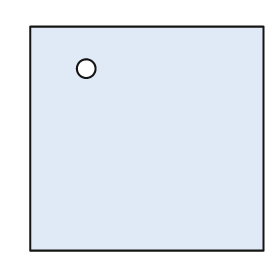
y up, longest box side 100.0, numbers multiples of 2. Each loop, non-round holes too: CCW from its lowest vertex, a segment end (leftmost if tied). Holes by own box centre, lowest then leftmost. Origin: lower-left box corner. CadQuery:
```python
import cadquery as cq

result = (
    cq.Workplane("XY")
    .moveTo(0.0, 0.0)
    .lineTo(100.0, 0.0)
    .lineTo(100.0, 96.0)
    .lineTo(0.0, 96.0)
    .close()
    .moveTo(24.0, 78.0)
    .circle(4.0)
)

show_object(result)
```